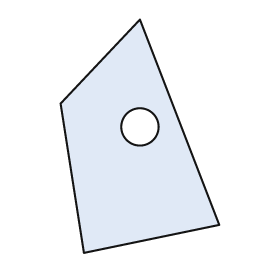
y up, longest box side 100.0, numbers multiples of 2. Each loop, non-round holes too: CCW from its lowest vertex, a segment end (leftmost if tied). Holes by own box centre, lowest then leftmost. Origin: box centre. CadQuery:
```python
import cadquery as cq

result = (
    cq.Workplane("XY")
    .moveTo(-24.0, -50.0)
    .lineTo(34.0, -38.0)
    .lineTo(0.0, 50.0)
    .lineTo(-34.0, 14.0)
    .close()
    .moveTo(0.0, 4.0)
    .circle(8.0)
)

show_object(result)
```